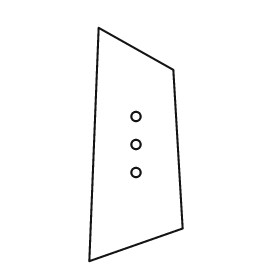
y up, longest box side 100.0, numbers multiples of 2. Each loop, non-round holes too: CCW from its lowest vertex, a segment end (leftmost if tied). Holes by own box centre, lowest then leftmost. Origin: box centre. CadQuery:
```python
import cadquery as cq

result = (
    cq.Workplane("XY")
    .moveTo(-20.0, -50.0)
    .lineTo(20.0, -36.0)
    .lineTo(16.0, 32.0)
    .lineTo(-16.0, 50.0)
    .close()
    .moveTo(0.0, -12.0)
    .circle(2.0)
    .moveTo(0.0, 0.0)
    .circle(2.0)
    .moveTo(0.0, 12.0)
    .circle(2.0)
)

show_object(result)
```